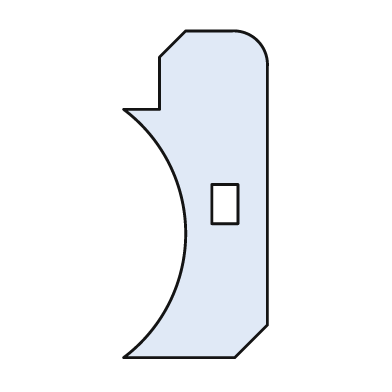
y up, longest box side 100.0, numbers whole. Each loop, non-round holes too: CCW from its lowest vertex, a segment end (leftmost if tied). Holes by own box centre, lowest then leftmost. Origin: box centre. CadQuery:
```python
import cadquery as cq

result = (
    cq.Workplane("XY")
    .moveTo(-22.0, -50.0)
    .lineTo(12.0, -50.0)
    .lineTo(22.0, -40.0)
    .lineTo(22.0, 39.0)
    .threePointArc((19.0, 47.0), (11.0, 50.0))
    .lineTo(-3.0, 50.0)
    .lineTo(-11.0, 42.0)
    .lineTo(-11.0, 26.0)
    .lineTo(-22.0, 26.0)
    .threePointArc((-3.0, -12.0), (-22.0, -50.0))
    .close()
    .moveTo(5.0, -9.0)
    .lineTo(13.0, -9.0)
    .lineTo(13.0, 3.0)
    .lineTo(5.0, 3.0)
    .close()
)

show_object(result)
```